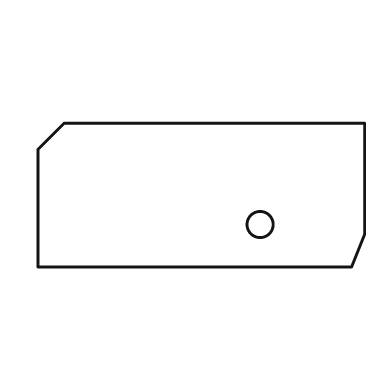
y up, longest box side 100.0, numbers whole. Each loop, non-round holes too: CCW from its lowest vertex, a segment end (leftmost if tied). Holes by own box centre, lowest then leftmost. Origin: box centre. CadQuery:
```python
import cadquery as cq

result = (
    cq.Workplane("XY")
    .moveTo(-50.0, -22.0)
    .lineTo(46.0, -22.0)
    .lineTo(50.0, -12.0)
    .lineTo(50.0, 22.0)
    .lineTo(-42.0, 22.0)
    .lineTo(-50.0, 14.0)
    .close()
    .moveTo(18.0, -9.0)
    .circle(4.0)
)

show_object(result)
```